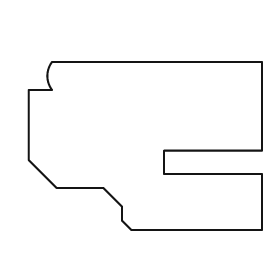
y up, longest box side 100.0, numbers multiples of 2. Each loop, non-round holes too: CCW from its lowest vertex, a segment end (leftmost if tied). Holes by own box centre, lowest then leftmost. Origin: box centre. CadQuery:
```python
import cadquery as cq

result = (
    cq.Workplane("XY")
    .moveTo(-6.0, -36.0)
    .lineTo(50.0, -36.0)
    .lineTo(50.0, -12.0)
    .lineTo(8.0, -12.0)
    .lineTo(8.0, -2.0)
    .lineTo(50.0, -2.0)
    .lineTo(50.0, 36.0)
    .lineTo(-40.0, 36.0)
    .threePointArc((-42.0, 30.0), (-40.0, 24.0))
    .lineTo(-50.0, 24.0)
    .lineTo(-50.0, -6.0)
    .lineTo(-38.0, -18.0)
    .lineTo(-18.0, -18.0)
    .lineTo(-10.0, -26.0)
    .lineTo(-10.0, -32.0)
    .close()
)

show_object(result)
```